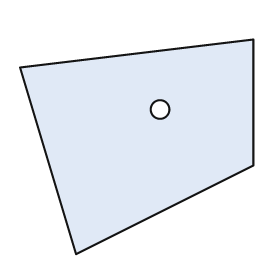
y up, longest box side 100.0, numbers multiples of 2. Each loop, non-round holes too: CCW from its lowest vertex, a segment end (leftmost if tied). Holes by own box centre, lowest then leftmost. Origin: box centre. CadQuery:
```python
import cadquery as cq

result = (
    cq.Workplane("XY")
    .moveTo(-26.0, -46.0)
    .lineTo(50.0, -8.0)
    .lineTo(50.0, 46.0)
    .lineTo(-50.0, 34.0)
    .close()
    .moveTo(10.0, 16.0)
    .circle(4.0)
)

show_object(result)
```